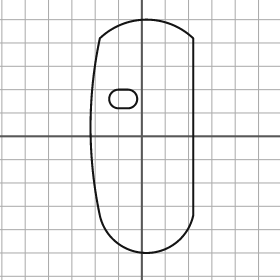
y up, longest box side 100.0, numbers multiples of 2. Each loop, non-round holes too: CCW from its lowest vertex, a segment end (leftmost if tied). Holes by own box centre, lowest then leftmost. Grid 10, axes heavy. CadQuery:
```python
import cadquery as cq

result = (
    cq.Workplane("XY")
    .moveTo(-18.0, -34.0)
    .threePointArc((2.0, -50.0), (22.0, -34.0))
    .lineTo(22.0, 42.0)
    .threePointArc((2.0, 50.0), (-18.0, 42.0))
    .threePointArc((-22.0, 4.0), (-18.0, -34.0))
    .close()
    .moveTo(-10.0, 12.0)
    .lineTo(-6.0, 12.0)
    .threePointArc((-2.0, 16.0), (-6.0, 20.0))
    .lineTo(-10.0, 20.0)
    .threePointArc((-14.0, 16.0), (-10.0, 12.0))
    .close()
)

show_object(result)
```